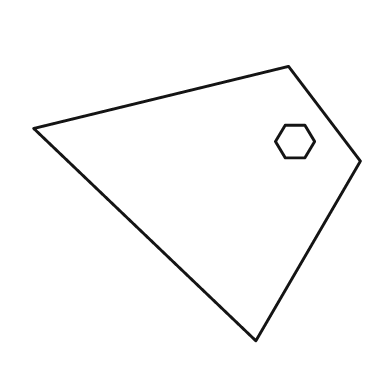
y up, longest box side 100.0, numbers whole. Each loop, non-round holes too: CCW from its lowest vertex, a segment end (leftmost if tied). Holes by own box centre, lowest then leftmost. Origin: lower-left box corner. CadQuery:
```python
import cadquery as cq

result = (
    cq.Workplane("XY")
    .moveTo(68.0, 0.0)
    .lineTo(100.0, 55.0)
    .lineTo(78.0, 84.0)
    .lineTo(0.0, 65.0)
    .close()
    .moveTo(77.0, 56.0)
    .lineTo(83.0, 56.0)
    .lineTo(86.0, 61.0)
    .lineTo(83.0, 66.0)
    .lineTo(77.0, 66.0)
    .lineTo(74.0, 61.0)
    .close()
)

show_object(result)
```